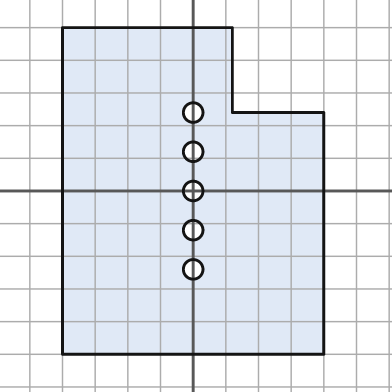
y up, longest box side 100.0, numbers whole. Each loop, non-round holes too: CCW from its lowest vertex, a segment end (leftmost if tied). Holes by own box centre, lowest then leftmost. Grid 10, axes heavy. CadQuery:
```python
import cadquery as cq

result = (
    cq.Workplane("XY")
    .moveTo(-40.0, -50.0)
    .lineTo(40.0, -50.0)
    .lineTo(40.0, 24.0)
    .lineTo(12.0, 24.0)
    .lineTo(12.0, 50.0)
    .lineTo(-40.0, 50.0)
    .close()
    .moveTo(0.0, -24.0)
    .circle(3.0)
    .moveTo(0.0, -12.0)
    .circle(3.0)
    .moveTo(0.0, 0.0)
    .circle(3.0)
    .moveTo(0.0, 12.0)
    .circle(3.0)
    .moveTo(0.0, 24.0)
    .circle(3.0)
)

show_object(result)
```